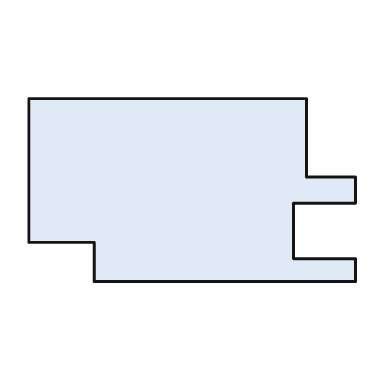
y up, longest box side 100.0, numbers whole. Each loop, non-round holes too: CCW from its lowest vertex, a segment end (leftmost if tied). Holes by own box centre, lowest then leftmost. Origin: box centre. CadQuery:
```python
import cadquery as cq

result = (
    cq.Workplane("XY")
    .moveTo(-30.0, -28.0)
    .lineTo(50.0, -28.0)
    .lineTo(50.0, -21.0)
    .lineTo(31.0, -21.0)
    .lineTo(31.0, -4.0)
    .lineTo(50.0, -4.0)
    .lineTo(50.0, 4.0)
    .lineTo(35.0, 4.0)
    .lineTo(35.0, 28.0)
    .lineTo(-50.0, 28.0)
    .lineTo(-50.0, -16.0)
    .lineTo(-30.0, -16.0)
    .close()
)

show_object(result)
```